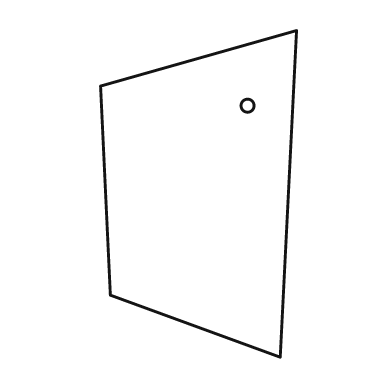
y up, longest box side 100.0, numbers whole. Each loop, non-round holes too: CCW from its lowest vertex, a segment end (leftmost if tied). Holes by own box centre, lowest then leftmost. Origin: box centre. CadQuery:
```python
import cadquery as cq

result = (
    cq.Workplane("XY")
    .moveTo(25.0, -50.0)
    .lineTo(30.0, 50.0)
    .lineTo(-30.0, 33.0)
    .lineTo(-27.0, -31.0)
    .close()
    .moveTo(15.0, 27.0)
    .circle(2.0)
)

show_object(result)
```